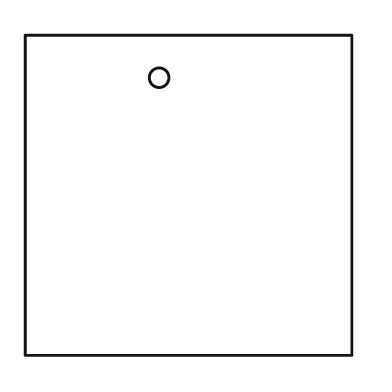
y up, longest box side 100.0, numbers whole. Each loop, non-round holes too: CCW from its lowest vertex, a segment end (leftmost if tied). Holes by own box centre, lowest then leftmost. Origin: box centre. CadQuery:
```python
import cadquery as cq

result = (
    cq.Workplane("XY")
    .moveTo(-50.0, -49.0)
    .lineTo(50.0, -49.0)
    .lineTo(50.0, 49.0)
    .lineTo(-50.0, 49.0)
    .close()
    .moveTo(-9.0, 36.0)
    .circle(3.0)
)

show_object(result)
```